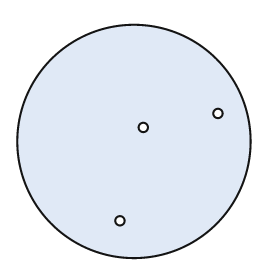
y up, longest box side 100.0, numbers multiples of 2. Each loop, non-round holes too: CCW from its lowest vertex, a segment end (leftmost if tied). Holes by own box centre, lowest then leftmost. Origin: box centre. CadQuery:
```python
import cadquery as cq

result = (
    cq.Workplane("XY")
    .moveTo(0.0, 0.0)
    .circle(50.0)
    .moveTo(-6.0, -34.0)
    .circle(2.0)
    .moveTo(4.0, 6.0)
    .circle(2.0)
    .moveTo(36.0, 12.0)
    .circle(2.0)
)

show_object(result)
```